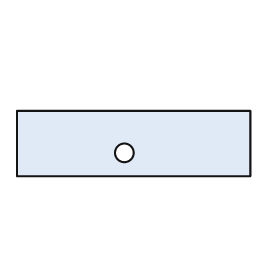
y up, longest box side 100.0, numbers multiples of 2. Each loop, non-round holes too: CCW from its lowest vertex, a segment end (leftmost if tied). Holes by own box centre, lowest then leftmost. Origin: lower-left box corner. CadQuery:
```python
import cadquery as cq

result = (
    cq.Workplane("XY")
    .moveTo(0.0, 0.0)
    .lineTo(100.0, 0.0)
    .lineTo(100.0, 28.0)
    .lineTo(0.0, 28.0)
    .close()
    .moveTo(46.0, 10.0)
    .circle(4.0)
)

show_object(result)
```